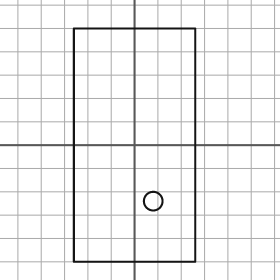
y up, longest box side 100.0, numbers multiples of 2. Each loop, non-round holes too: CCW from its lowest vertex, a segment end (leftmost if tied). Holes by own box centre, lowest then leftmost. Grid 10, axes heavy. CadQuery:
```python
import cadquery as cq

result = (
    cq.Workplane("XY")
    .moveTo(-26.0, -50.0)
    .lineTo(26.0, -50.0)
    .lineTo(26.0, 50.0)
    .lineTo(-26.0, 50.0)
    .close()
    .moveTo(8.0, -24.0)
    .circle(4.0)
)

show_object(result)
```